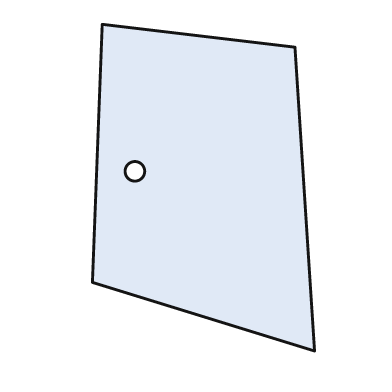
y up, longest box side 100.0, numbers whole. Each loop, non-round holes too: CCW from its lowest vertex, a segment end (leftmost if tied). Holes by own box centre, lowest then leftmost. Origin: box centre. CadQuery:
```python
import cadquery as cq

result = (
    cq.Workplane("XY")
    .moveTo(34.0, -50.0)
    .lineTo(28.0, 43.0)
    .lineTo(-31.0, 50.0)
    .lineTo(-34.0, -29.0)
    .close()
    .moveTo(-21.0, 5.0)
    .circle(3.0)
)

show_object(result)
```